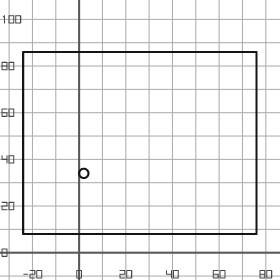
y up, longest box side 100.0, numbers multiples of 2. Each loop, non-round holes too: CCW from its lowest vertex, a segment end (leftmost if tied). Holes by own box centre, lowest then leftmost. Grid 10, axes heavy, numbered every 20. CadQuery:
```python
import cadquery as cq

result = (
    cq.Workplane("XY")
    .moveTo(-24.0, 8.0)
    .lineTo(76.0, 8.0)
    .lineTo(76.0, 86.0)
    .lineTo(-24.0, 86.0)
    .close()
    .moveTo(2.0, 34.0)
    .circle(2.0)
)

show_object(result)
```